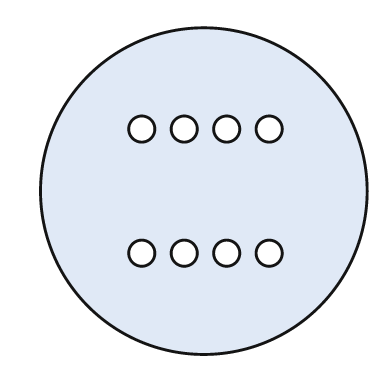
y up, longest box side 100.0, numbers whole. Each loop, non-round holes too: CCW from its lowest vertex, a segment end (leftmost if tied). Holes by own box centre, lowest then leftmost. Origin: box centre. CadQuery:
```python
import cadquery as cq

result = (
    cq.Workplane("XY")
    .moveTo(0.0, 0.0)
    .circle(50.0)
    .moveTo(-19.0, -19.0)
    .circle(4.0)
    .moveTo(-6.0, -19.0)
    .circle(4.0)
    .moveTo(7.0, -19.0)
    .circle(4.0)
    .moveTo(20.0, -19.0)
    .circle(4.0)
    .moveTo(-19.0, 19.0)
    .circle(4.0)
    .moveTo(-6.0, 19.0)
    .circle(4.0)
    .moveTo(7.0, 19.0)
    .circle(4.0)
    .moveTo(20.0, 19.0)
    .circle(4.0)
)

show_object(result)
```